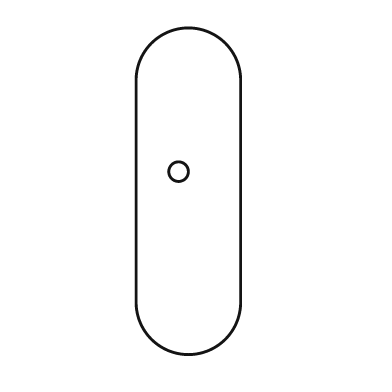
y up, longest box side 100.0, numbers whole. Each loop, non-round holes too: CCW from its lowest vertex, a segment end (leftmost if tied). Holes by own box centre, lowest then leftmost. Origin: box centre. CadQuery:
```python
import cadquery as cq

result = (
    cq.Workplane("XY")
    .moveTo(-16.0, -34.0)
    .threePointArc((0.0, -50.0), (16.0, -34.0))
    .lineTo(16.0, 34.0)
    .threePointArc((0.0, 50.0), (-16.0, 34.0))
    .close()
    .moveTo(-3.0, 6.0)
    .circle(3.0)
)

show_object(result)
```